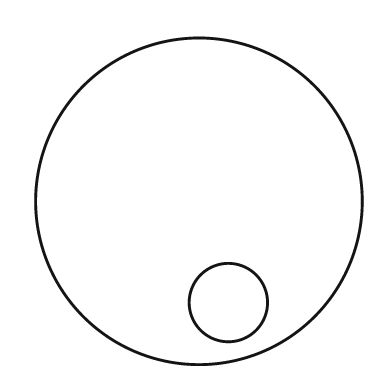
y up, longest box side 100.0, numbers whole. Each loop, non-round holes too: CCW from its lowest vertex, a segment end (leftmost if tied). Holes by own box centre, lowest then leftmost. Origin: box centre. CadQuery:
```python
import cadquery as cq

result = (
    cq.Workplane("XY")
    .moveTo(0.0, 0.0)
    .circle(50.0)
    .moveTo(9.0, -31.0)
    .circle(12.0)
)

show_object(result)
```